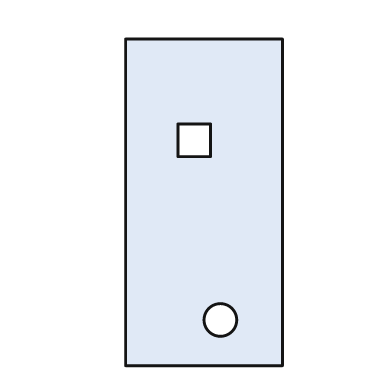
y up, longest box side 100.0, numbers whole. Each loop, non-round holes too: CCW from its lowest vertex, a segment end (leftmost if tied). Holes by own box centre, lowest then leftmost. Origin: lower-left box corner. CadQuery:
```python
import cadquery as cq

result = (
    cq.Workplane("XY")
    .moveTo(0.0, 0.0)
    .lineTo(48.0, 0.0)
    .lineTo(48.0, 100.0)
    .lineTo(0.0, 100.0)
    .close()
    .moveTo(29.0, 14.0)
    .circle(5.0)
    .moveTo(16.0, 64.0)
    .lineTo(26.0, 64.0)
    .lineTo(26.0, 74.0)
    .lineTo(16.0, 74.0)
    .close()
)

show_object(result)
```